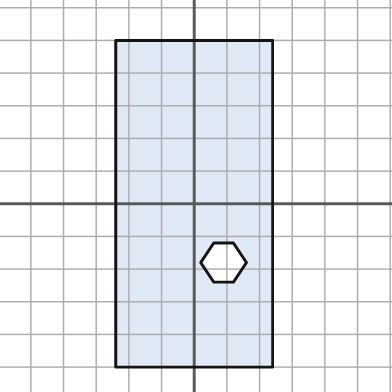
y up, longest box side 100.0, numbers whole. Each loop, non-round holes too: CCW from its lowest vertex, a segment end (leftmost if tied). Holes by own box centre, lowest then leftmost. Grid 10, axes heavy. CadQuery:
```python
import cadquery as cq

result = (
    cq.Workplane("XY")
    .moveTo(-24.0, -50.0)
    .lineTo(24.0, -50.0)
    .lineTo(24.0, 50.0)
    .lineTo(-24.0, 50.0)
    .close()
    .moveTo(6.0, -24.0)
    .lineTo(12.0, -24.0)
    .lineTo(16.0, -18.0)
    .lineTo(12.0, -12.0)
    .lineTo(6.0, -12.0)
    .lineTo(2.0, -18.0)
    .close()
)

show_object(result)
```